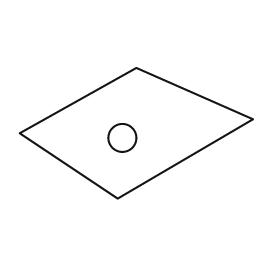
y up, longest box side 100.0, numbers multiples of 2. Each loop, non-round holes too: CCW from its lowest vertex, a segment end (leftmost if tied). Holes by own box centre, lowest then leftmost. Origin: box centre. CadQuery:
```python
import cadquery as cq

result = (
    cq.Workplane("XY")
    .moveTo(-8.0, -28.0)
    .lineTo(50.0, 6.0)
    .lineTo(0.0, 28.0)
    .lineTo(-50.0, 0.0)
    .close()
    .moveTo(-6.0, -2.0)
    .circle(6.0)
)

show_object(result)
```